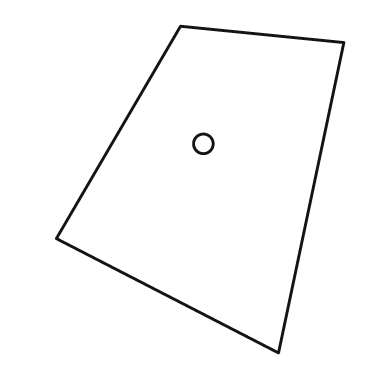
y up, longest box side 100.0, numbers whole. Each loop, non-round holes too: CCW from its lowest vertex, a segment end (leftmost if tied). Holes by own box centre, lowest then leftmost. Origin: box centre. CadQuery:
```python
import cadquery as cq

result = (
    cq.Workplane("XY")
    .moveTo(24.0, -50.0)
    .lineTo(44.0, 45.0)
    .lineTo(-6.0, 50.0)
    .lineTo(-44.0, -15.0)
    .close()
    .moveTo(1.0, 14.0)
    .circle(3.0)
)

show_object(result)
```